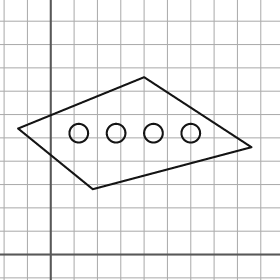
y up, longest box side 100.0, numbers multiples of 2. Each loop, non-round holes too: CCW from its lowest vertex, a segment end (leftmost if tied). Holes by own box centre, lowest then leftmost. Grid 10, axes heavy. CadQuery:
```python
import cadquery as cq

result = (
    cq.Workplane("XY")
    .moveTo(18.0, 28.0)
    .lineTo(86.0, 46.0)
    .lineTo(40.0, 76.0)
    .lineTo(-14.0, 54.0)
    .close()
    .moveTo(12.0, 52.0)
    .circle(4.0)
    .moveTo(28.0, 52.0)
    .circle(4.0)
    .moveTo(44.0, 52.0)
    .circle(4.0)
    .moveTo(60.0, 52.0)
    .circle(4.0)
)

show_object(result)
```